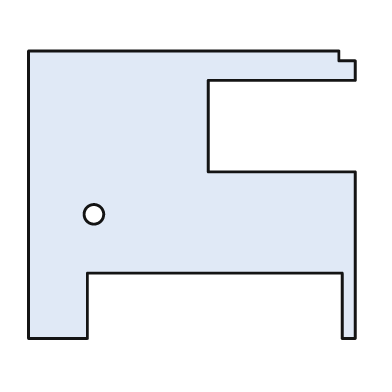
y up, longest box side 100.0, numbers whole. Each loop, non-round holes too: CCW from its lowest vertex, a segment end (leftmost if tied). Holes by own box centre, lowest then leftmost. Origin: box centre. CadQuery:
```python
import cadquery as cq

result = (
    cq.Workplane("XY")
    .moveTo(-50.0, -44.0)
    .lineTo(-32.0, -44.0)
    .lineTo(-32.0, -24.0)
    .lineTo(46.0, -24.0)
    .lineTo(46.0, -44.0)
    .lineTo(50.0, -44.0)
    .lineTo(50.0, 7.0)
    .lineTo(5.0, 7.0)
    .lineTo(5.0, 35.0)
    .lineTo(50.0, 35.0)
    .lineTo(50.0, 41.0)
    .lineTo(45.0, 41.0)
    .lineTo(45.0, 44.0)
    .lineTo(-50.0, 44.0)
    .close()
    .moveTo(-30.0, -6.0)
    .circle(3.0)
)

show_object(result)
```